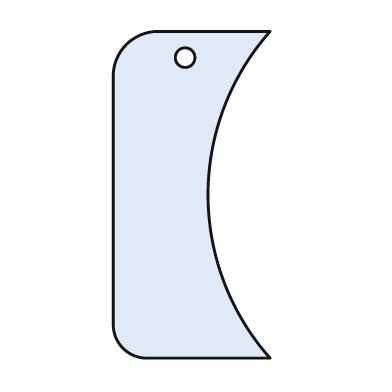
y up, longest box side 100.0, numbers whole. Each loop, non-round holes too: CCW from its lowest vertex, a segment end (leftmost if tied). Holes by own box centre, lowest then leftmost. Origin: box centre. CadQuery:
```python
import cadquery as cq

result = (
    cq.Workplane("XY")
    .moveTo(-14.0, -50.0)
    .lineTo(24.0, -50.0)
    .threePointArc((5.0, 0.0), (24.0, 50.0))
    .lineTo(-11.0, 50.0)
    .threePointArc((-20.0, 46.0), (-24.0, 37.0))
    .lineTo(-24.0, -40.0)
    .threePointArc((-21.0, -47.0), (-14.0, -50.0))
    .close()
    .moveTo(-2.0, 42.0)
    .circle(3.0)
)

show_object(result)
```